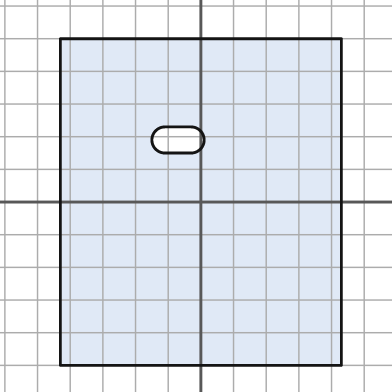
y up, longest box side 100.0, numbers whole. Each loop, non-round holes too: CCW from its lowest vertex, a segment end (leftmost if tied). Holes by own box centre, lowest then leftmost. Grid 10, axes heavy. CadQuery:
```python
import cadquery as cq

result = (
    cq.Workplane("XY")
    .moveTo(-43.0, -50.0)
    .lineTo(43.0, -50.0)
    .lineTo(43.0, 50.0)
    .lineTo(-43.0, 50.0)
    .close()
    .moveTo(-11.0, 15.0)
    .lineTo(-3.0, 15.0)
    .threePointArc((1.0, 19.0), (-3.0, 23.0))
    .lineTo(-11.0, 23.0)
    .threePointArc((-15.0, 19.0), (-11.0, 15.0))
    .close()
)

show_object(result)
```